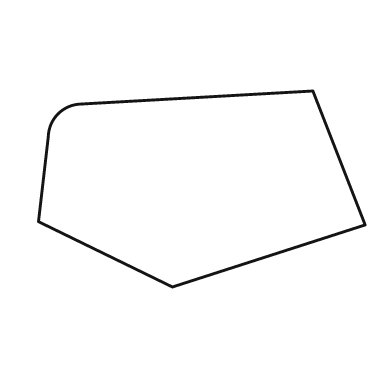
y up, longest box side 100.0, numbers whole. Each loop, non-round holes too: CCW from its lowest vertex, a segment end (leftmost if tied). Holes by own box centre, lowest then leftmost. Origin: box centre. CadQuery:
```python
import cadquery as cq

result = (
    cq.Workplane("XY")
    .moveTo(-9.0, -30.0)
    .lineTo(50.0, -11.0)
    .lineTo(34.0, 30.0)
    .lineTo(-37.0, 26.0)
    .threePointArc((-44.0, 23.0), (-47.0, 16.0))
    .lineTo(-50.0, -10.0)
    .close()
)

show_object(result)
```